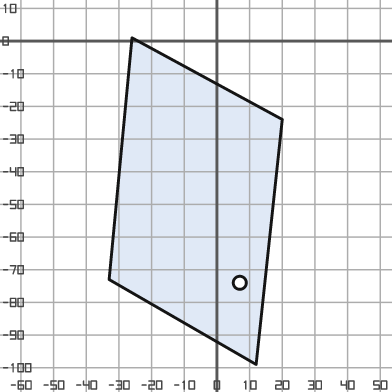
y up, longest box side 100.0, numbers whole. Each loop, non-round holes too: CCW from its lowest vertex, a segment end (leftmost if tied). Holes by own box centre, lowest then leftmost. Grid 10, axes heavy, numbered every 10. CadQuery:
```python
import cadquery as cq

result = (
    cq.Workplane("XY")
    .moveTo(12.0, -99.0)
    .lineTo(20.0, -24.0)
    .lineTo(-26.0, 1.0)
    .lineTo(-33.0, -73.0)
    .close()
    .moveTo(7.0, -74.0)
    .circle(2.0)
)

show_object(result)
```